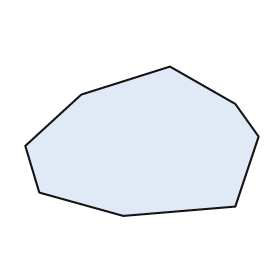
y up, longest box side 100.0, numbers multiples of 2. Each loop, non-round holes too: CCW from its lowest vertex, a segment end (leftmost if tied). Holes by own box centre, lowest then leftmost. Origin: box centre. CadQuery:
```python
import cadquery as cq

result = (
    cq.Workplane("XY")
    .moveTo(-8.0, -32.0)
    .lineTo(40.0, -28.0)
    .lineTo(50.0, 2.0)
    .lineTo(40.0, 16.0)
    .lineTo(12.0, 32.0)
    .lineTo(-26.0, 20.0)
    .lineTo(-50.0, -2.0)
    .lineTo(-44.0, -22.0)
    .close()
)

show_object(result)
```